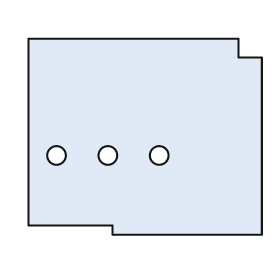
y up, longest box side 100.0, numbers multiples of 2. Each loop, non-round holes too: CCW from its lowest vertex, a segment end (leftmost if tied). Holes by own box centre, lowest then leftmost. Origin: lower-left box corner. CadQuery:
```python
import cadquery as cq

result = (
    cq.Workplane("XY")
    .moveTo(36.0, 0.0)
    .lineTo(100.0, 0.0)
    .lineTo(100.0, 76.0)
    .lineTo(90.0, 76.0)
    .lineTo(90.0, 84.0)
    .lineTo(0.0, 84.0)
    .lineTo(0.0, 4.0)
    .lineTo(36.0, 4.0)
    .close()
    .moveTo(12.0, 34.0)
    .circle(4.0)
    .moveTo(34.0, 34.0)
    .circle(4.0)
    .moveTo(56.0, 34.0)
    .circle(4.0)
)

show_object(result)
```